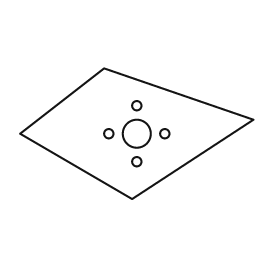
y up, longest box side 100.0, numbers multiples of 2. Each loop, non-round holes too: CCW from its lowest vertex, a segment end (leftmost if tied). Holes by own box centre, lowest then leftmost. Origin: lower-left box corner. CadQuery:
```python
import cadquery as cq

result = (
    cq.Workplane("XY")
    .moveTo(48.0, 0.0)
    .lineTo(100.0, 34.0)
    .lineTo(36.0, 56.0)
    .lineTo(0.0, 28.0)
    .close()
    .moveTo(50.0, 16.0)
    .circle(2.0)
    .moveTo(38.0, 28.0)
    .circle(2.0)
    .moveTo(50.0, 28.0)
    .circle(6.0)
    .moveTo(62.0, 28.0)
    .circle(2.0)
    .moveTo(50.0, 40.0)
    .circle(2.0)
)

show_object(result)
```